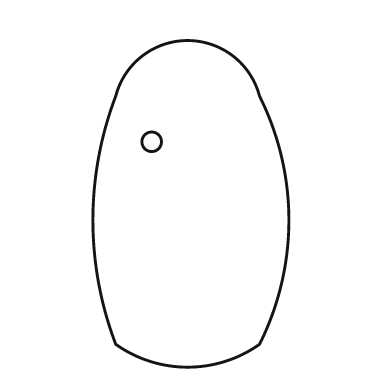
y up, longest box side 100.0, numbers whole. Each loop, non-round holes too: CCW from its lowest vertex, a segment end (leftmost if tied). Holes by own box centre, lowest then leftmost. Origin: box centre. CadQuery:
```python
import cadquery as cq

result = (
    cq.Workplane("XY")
    .moveTo(-23.0, -43.0)
    .threePointArc((-1.0, -50.0), (21.0, -43.0))
    .threePointArc((30.0, -5.0), (21.0, 33.0))
    .threePointArc((-1.0, 50.0), (-23.0, 33.0))
    .threePointArc((-30.0, -5.0), (-23.0, -43.0))
    .close()
    .moveTo(-12.0, 19.0)
    .circle(3.0)
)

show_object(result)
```